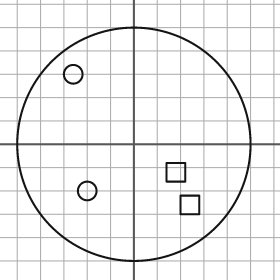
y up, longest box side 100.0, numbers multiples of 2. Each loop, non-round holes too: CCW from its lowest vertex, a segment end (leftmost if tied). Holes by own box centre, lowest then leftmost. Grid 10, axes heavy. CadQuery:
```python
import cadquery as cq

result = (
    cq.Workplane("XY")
    .moveTo(0.0, 0.0)
    .circle(50.0)
    .moveTo(20.0, -30.0)
    .lineTo(28.0, -30.0)
    .lineTo(28.0, -22.0)
    .lineTo(20.0, -22.0)
    .close()
    .moveTo(-20.0, -20.0)
    .circle(4.0)
    .moveTo(14.0, -16.0)
    .lineTo(22.0, -16.0)
    .lineTo(22.0, -8.0)
    .lineTo(14.0, -8.0)
    .close()
    .moveTo(-26.0, 30.0)
    .circle(4.0)
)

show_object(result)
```